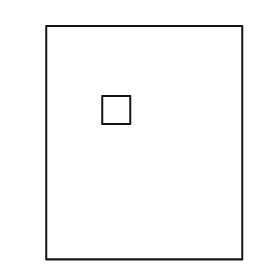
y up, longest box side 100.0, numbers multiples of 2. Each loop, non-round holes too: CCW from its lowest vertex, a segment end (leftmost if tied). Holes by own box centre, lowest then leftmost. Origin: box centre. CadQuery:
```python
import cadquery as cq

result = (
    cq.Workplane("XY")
    .moveTo(-42.0, -50.0)
    .lineTo(42.0, -50.0)
    .lineTo(42.0, 50.0)
    .lineTo(-42.0, 50.0)
    .close()
    .moveTo(-18.0, 8.0)
    .lineTo(-6.0, 8.0)
    .lineTo(-6.0, 20.0)
    .lineTo(-18.0, 20.0)
    .close()
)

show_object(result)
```